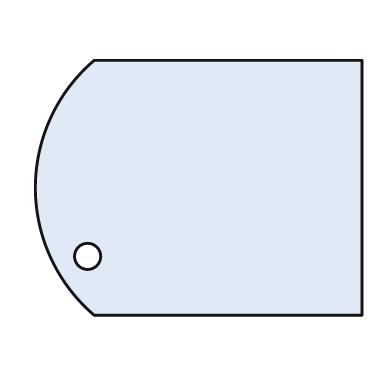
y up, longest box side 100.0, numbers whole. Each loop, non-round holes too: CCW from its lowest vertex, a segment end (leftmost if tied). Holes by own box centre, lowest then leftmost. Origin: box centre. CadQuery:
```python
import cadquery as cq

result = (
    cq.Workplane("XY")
    .moveTo(-32.0, -39.0)
    .lineTo(50.0, -39.0)
    .lineTo(50.0, 39.0)
    .lineTo(-32.0, 39.0)
    .threePointArc((-50.0, 0.0), (-32.0, -39.0))
    .close()
    .moveTo(-34.0, -21.0)
    .circle(4.0)
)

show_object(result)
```